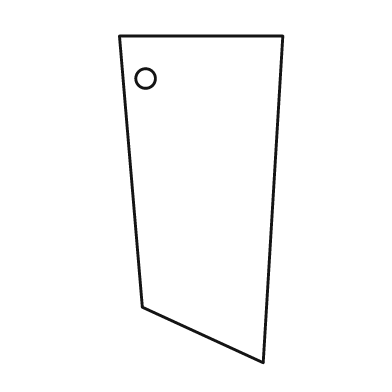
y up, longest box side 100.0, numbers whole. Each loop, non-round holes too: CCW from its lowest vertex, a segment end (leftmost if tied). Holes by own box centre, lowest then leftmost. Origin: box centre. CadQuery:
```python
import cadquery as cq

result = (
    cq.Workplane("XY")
    .moveTo(19.0, -50.0)
    .lineTo(25.0, 50.0)
    .lineTo(-25.0, 50.0)
    .lineTo(-18.0, -33.0)
    .close()
    .moveTo(-17.0, 37.0)
    .circle(3.0)
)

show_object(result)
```